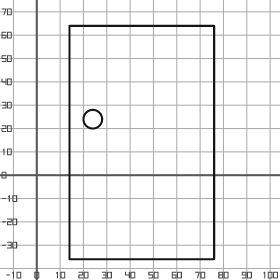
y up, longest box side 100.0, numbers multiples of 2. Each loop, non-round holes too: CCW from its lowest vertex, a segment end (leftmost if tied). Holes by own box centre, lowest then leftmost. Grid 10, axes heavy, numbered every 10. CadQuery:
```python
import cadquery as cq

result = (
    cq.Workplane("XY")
    .moveTo(14.0, -36.0)
    .lineTo(76.0, -36.0)
    .lineTo(76.0, 64.0)
    .lineTo(14.0, 64.0)
    .close()
    .moveTo(24.0, 24.0)
    .circle(4.0)
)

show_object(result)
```